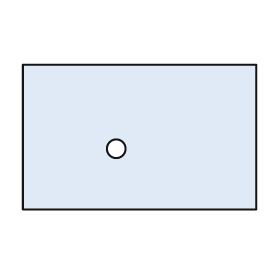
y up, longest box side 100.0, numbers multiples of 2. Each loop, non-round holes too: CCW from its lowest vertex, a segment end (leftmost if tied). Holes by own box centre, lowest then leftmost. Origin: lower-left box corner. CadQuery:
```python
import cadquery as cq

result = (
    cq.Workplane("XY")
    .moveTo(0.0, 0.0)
    .lineTo(100.0, 0.0)
    .lineTo(100.0, 62.0)
    .lineTo(0.0, 62.0)
    .close()
    .moveTo(40.0, 26.0)
    .circle(4.0)
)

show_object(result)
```